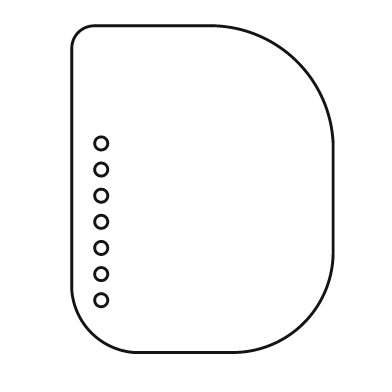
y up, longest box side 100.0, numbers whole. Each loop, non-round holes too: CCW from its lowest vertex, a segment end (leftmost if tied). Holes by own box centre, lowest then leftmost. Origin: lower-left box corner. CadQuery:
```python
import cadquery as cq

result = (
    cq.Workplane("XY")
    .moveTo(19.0, 0.0)
    .lineTo(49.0, 0.0)
    .threePointArc((71.0, 9.0), (80.0, 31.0))
    .lineTo(80.0, 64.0)
    .threePointArc((69.0, 89.0), (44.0, 100.0))
    .lineTo(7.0, 100.0)
    .threePointArc((2.0, 98.0), (0.0, 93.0))
    .lineTo(0.0, 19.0)
    .threePointArc((6.0, 6.0), (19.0, 0.0))
    .close()
    .moveTo(9.0, 16.0)
    .circle(2.0)
    .moveTo(9.0, 24.0)
    .circle(2.0)
    .moveTo(9.0, 32.0)
    .circle(2.0)
    .moveTo(9.0, 40.0)
    .circle(2.0)
    .moveTo(9.0, 48.0)
    .circle(2.0)
    .moveTo(9.0, 56.0)
    .circle(2.0)
    .moveTo(9.0, 64.0)
    .circle(2.0)
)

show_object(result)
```